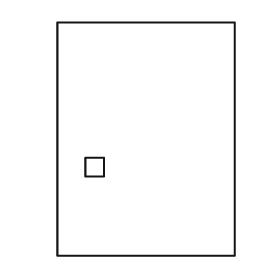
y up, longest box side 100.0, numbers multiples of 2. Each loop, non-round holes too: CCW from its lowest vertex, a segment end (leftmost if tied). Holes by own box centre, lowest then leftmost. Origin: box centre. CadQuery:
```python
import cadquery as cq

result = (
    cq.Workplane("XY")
    .moveTo(-38.0, -50.0)
    .lineTo(38.0, -50.0)
    .lineTo(38.0, 50.0)
    .lineTo(-38.0, 50.0)
    .close()
    .moveTo(-26.0, -16.0)
    .lineTo(-18.0, -16.0)
    .lineTo(-18.0, -8.0)
    .lineTo(-26.0, -8.0)
    .close()
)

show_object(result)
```